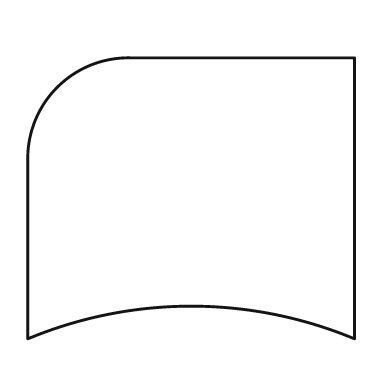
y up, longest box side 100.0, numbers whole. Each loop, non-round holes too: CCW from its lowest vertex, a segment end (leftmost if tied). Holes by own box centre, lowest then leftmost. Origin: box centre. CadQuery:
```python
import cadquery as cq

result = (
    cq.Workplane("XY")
    .moveTo(-50.0, -43.0)
    .threePointArc((0.0, -33.0), (50.0, -43.0))
    .lineTo(50.0, 43.0)
    .lineTo(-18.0, 43.0)
    .threePointArc((-41.0, 34.0), (-50.0, 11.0))
    .close()
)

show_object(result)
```